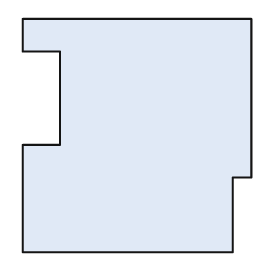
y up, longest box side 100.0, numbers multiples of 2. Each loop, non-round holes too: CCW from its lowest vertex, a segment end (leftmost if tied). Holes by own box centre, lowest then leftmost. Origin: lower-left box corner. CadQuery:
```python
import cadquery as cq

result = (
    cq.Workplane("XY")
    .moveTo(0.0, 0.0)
    .lineTo(90.0, 0.0)
    .lineTo(90.0, 32.0)
    .lineTo(98.0, 32.0)
    .lineTo(98.0, 100.0)
    .lineTo(0.0, 100.0)
    .lineTo(0.0, 86.0)
    .lineTo(16.0, 86.0)
    .lineTo(16.0, 46.0)
    .lineTo(0.0, 46.0)
    .close()
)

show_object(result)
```